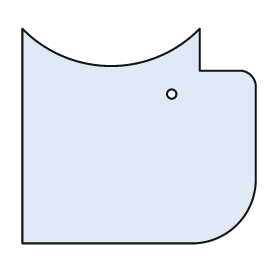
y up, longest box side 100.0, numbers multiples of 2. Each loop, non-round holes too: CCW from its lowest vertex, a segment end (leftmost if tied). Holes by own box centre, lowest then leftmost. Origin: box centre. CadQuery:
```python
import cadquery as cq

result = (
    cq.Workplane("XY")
    .moveTo(-50.0, -46.0)
    .lineTo(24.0, -46.0)
    .threePointArc((42.0, -38.0), (50.0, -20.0))
    .lineTo(50.0, 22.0)
    .threePointArc((48.0, 26.0), (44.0, 28.0))
    .lineTo(26.0, 28.0)
    .lineTo(26.0, 46.0)
    .threePointArc((-12.0, 30.0), (-50.0, 46.0))
    .close()
    .moveTo(14.0, 18.0)
    .circle(2.0)
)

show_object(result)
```